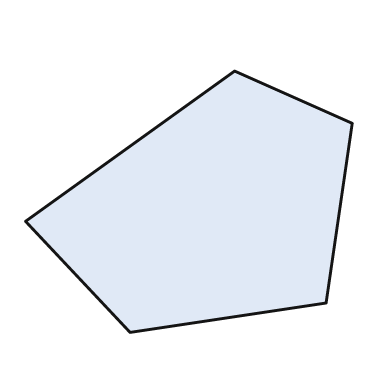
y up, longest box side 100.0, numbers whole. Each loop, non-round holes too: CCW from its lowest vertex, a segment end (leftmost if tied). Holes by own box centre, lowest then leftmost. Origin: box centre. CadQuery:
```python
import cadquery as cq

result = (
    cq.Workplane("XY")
    .moveTo(-18.0, -40.0)
    .lineTo(42.0, -31.0)
    .lineTo(50.0, 24.0)
    .lineTo(14.0, 40.0)
    .lineTo(-50.0, -6.0)
    .close()
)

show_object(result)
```